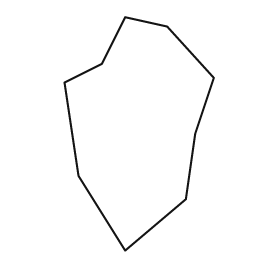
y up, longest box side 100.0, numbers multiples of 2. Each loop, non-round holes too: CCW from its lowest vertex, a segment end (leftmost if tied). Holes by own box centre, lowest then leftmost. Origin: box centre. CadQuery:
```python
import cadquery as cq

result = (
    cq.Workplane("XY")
    .moveTo(-6.0, -50.0)
    .lineTo(20.0, -28.0)
    .lineTo(24.0, 0.0)
    .lineTo(32.0, 24.0)
    .lineTo(12.0, 46.0)
    .lineTo(-6.0, 50.0)
    .lineTo(-16.0, 30.0)
    .lineTo(-32.0, 22.0)
    .lineTo(-26.0, -18.0)
    .close()
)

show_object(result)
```